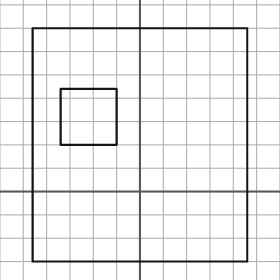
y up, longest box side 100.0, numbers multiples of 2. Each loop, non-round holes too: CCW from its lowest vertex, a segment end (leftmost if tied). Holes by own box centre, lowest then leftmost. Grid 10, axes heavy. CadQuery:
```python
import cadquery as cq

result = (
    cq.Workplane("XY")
    .moveTo(-46.0, -30.0)
    .lineTo(46.0, -30.0)
    .lineTo(46.0, 70.0)
    .lineTo(-46.0, 70.0)
    .close()
    .moveTo(-34.0, 20.0)
    .lineTo(-10.0, 20.0)
    .lineTo(-10.0, 44.0)
    .lineTo(-34.0, 44.0)
    .close()
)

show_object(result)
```